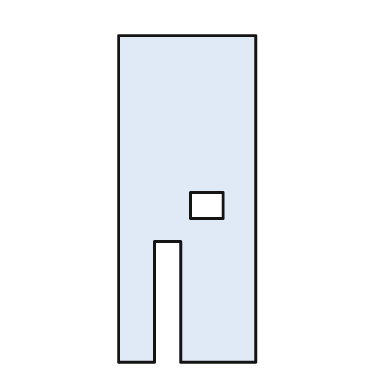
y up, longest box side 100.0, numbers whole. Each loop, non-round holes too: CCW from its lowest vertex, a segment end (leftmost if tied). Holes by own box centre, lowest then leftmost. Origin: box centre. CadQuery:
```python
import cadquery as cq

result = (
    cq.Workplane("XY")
    .moveTo(-21.0, -50.0)
    .lineTo(-10.0, -50.0)
    .lineTo(-10.0, -13.0)
    .lineTo(-2.0, -13.0)
    .lineTo(-2.0, -50.0)
    .lineTo(21.0, -50.0)
    .lineTo(21.0, 50.0)
    .lineTo(-21.0, 50.0)
    .close()
    .moveTo(1.0, -6.0)
    .lineTo(11.0, -6.0)
    .lineTo(11.0, 2.0)
    .lineTo(1.0, 2.0)
    .close()
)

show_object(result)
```